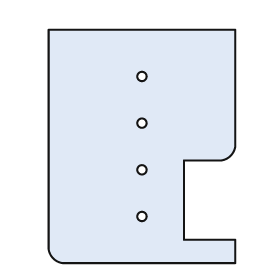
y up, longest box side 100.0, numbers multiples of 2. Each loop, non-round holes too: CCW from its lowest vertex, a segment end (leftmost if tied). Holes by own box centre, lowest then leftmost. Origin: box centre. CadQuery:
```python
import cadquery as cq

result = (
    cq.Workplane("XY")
    .moveTo(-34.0, -50.0)
    .lineTo(40.0, -50.0)
    .lineTo(40.0, -40.0)
    .lineTo(18.0, -40.0)
    .lineTo(18.0, -6.0)
    .lineTo(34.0, -6.0)
    .threePointArc((38.0, -4.0), (40.0, 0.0))
    .lineTo(40.0, 50.0)
    .lineTo(-40.0, 50.0)
    .lineTo(-40.0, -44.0)
    .threePointArc((-38.0, -48.0), (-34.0, -50.0))
    .close()
    .moveTo(0.0, -30.0)
    .circle(2.0)
    .moveTo(0.0, -10.0)
    .circle(2.0)
    .moveTo(0.0, 10.0)
    .circle(2.0)
    .moveTo(0.0, 30.0)
    .circle(2.0)
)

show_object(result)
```